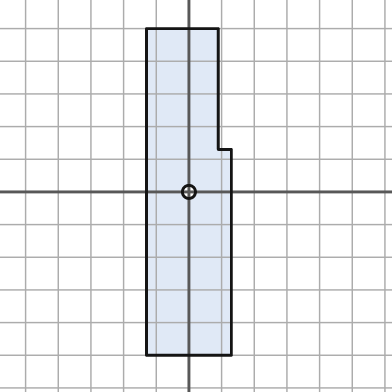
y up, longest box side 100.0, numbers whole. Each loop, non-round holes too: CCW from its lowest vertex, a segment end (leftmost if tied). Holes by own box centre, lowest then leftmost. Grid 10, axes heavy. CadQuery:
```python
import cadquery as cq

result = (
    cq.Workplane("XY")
    .moveTo(-13.0, -50.0)
    .lineTo(13.0, -50.0)
    .lineTo(13.0, 13.0)
    .lineTo(9.0, 13.0)
    .lineTo(9.0, 50.0)
    .lineTo(-13.0, 50.0)
    .close()
    .moveTo(0.0, 0.0)
    .circle(2.0)
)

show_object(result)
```